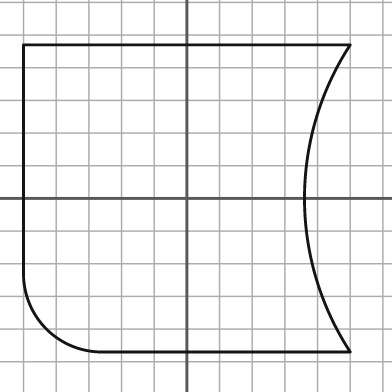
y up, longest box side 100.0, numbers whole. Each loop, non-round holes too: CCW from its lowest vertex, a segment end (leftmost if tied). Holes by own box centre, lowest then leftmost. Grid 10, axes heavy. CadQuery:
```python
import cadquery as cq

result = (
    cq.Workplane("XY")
    .moveTo(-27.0, -47.0)
    .lineTo(50.0, -47.0)
    .threePointArc((36.0, 0.0), (50.0, 47.0))
    .lineTo(-50.0, 47.0)
    .lineTo(-50.0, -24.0)
    .threePointArc((-43.0, -40.0), (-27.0, -47.0))
    .close()
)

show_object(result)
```